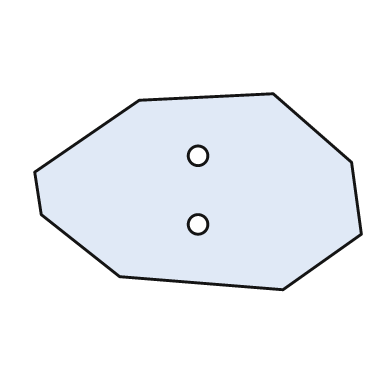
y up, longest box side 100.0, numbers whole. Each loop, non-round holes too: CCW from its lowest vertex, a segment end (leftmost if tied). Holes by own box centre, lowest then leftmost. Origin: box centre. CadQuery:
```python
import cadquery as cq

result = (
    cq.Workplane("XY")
    .moveTo(26.0, -30.0)
    .lineTo(50.0, -13.0)
    .lineTo(47.0, 9.0)
    .lineTo(23.0, 30.0)
    .lineTo(-18.0, 28.0)
    .lineTo(-50.0, 6.0)
    .lineTo(-48.0, -7.0)
    .lineTo(-24.0, -26.0)
    .close()
    .moveTo(0.0, -10.0)
    .circle(3.0)
    .moveTo(0.0, 11.0)
    .circle(3.0)
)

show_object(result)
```